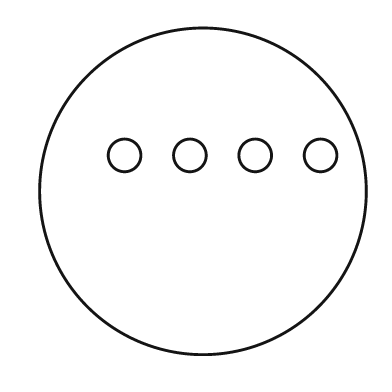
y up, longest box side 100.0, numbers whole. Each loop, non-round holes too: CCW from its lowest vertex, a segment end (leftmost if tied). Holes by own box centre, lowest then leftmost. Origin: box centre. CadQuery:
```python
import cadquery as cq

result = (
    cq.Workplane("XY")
    .moveTo(0.0, 0.0)
    .circle(50.0)
    .moveTo(-24.0, 11.0)
    .circle(5.0)
    .moveTo(-4.0, 11.0)
    .circle(5.0)
    .moveTo(16.0, 11.0)
    .circle(5.0)
    .moveTo(36.0, 11.0)
    .circle(5.0)
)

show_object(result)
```